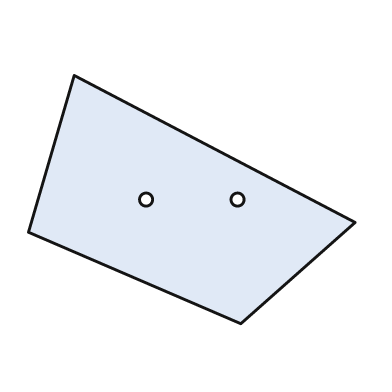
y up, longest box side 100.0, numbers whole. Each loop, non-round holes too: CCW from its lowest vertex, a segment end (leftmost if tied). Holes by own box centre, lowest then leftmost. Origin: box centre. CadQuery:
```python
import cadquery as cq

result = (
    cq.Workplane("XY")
    .moveTo(15.0, -38.0)
    .lineTo(50.0, -7.0)
    .lineTo(-36.0, 38.0)
    .lineTo(-50.0, -10.0)
    .close()
    .moveTo(-14.0, 0.0)
    .circle(2.0)
    .moveTo(14.0, 0.0)
    .circle(2.0)
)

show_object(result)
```